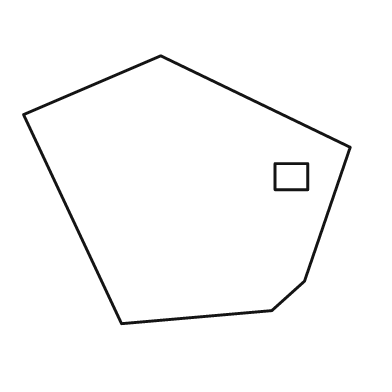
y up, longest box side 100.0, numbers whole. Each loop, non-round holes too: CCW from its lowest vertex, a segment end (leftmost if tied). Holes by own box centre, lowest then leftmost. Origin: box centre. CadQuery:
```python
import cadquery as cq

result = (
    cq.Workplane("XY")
    .moveTo(-20.0, -41.0)
    .lineTo(26.0, -37.0)
    .lineTo(36.0, -28.0)
    .lineTo(50.0, 13.0)
    .lineTo(-8.0, 41.0)
    .lineTo(-50.0, 23.0)
    .close()
    .moveTo(27.0, 0.0)
    .lineTo(37.0, 0.0)
    .lineTo(37.0, 8.0)
    .lineTo(27.0, 8.0)
    .close()
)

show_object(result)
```